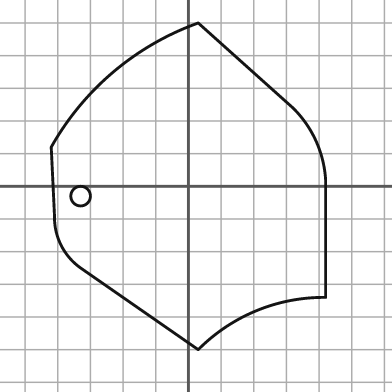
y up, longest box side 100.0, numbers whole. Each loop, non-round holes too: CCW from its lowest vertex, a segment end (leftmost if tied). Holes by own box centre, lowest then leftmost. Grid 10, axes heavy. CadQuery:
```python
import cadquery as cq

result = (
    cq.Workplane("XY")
    .moveTo(3.0, -50.0)
    .threePointArc((21.0, -38.0), (42.0, -34.0))
    .lineTo(42.0, 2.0)
    .threePointArc((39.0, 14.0), (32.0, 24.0))
    .lineTo(3.0, 50.0)
    .threePointArc((-23.0, 35.0), (-42.0, 12.0))
    .lineTo(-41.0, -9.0)
    .threePointArc((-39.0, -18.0), (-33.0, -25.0))
    .close()
    .moveTo(-33.0, -3.0)
    .circle(3.0)
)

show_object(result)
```